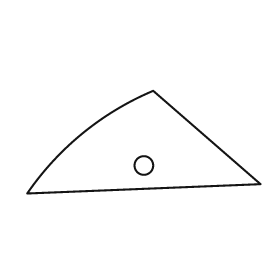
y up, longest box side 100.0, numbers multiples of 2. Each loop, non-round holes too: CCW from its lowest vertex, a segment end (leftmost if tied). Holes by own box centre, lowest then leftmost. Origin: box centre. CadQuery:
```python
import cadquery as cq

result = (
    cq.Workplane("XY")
    .moveTo(-50.0, -22.0)
    .lineTo(50.0, -18.0)
    .lineTo(4.0, 22.0)
    .threePointArc((-26.0, 4.0), (-50.0, -22.0))
    .close()
    .moveTo(0.0, -10.0)
    .circle(4.0)
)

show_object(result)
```